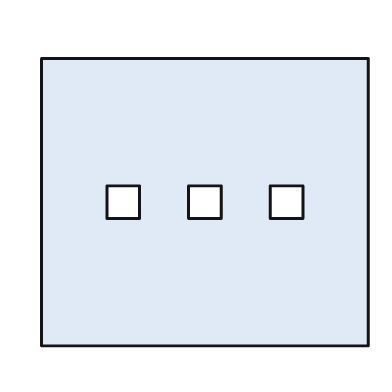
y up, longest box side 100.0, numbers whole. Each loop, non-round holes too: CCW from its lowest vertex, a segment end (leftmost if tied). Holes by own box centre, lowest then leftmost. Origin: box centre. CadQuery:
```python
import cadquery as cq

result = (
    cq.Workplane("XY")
    .moveTo(-50.0, -44.0)
    .lineTo(50.0, -44.0)
    .lineTo(50.0, 44.0)
    .lineTo(-50.0, 44.0)
    .close()
    .moveTo(-30.0, -5.0)
    .lineTo(-20.0, -5.0)
    .lineTo(-20.0, 5.0)
    .lineTo(-30.0, 5.0)
    .close()
    .moveTo(-5.0, -5.0)
    .lineTo(5.0, -5.0)
    .lineTo(5.0, 5.0)
    .lineTo(-5.0, 5.0)
    .close()
    .moveTo(20.0, -5.0)
    .lineTo(30.0, -5.0)
    .lineTo(30.0, 5.0)
    .lineTo(20.0, 5.0)
    .close()
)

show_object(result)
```